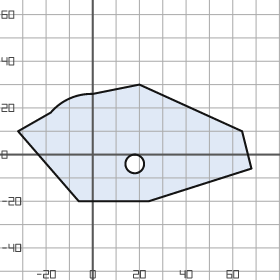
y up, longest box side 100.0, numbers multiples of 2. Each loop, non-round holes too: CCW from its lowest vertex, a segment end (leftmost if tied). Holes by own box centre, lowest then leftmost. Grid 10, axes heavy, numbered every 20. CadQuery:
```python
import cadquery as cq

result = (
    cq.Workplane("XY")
    .moveTo(-6.0, -20.0)
    .lineTo(24.0, -20.0)
    .lineTo(68.0, -6.0)
    .lineTo(64.0, 10.0)
    .lineTo(20.0, 30.0)
    .lineTo(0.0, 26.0)
    .threePointArc((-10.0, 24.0), (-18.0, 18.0))
    .lineTo(-32.0, 10.0)
    .close()
    .moveTo(18.0, -4.0)
    .circle(4.0)
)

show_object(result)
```